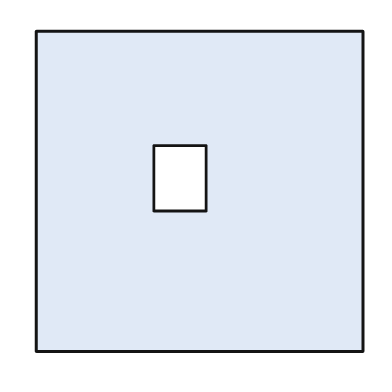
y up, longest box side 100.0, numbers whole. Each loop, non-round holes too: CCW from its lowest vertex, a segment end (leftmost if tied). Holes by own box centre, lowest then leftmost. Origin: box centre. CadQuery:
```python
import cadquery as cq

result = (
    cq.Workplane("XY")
    .moveTo(-50.0, -49.0)
    .lineTo(50.0, -49.0)
    .lineTo(50.0, 49.0)
    .lineTo(-50.0, 49.0)
    .close()
    .moveTo(-14.0, -6.0)
    .lineTo(2.0, -6.0)
    .lineTo(2.0, 14.0)
    .lineTo(-14.0, 14.0)
    .close()
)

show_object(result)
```